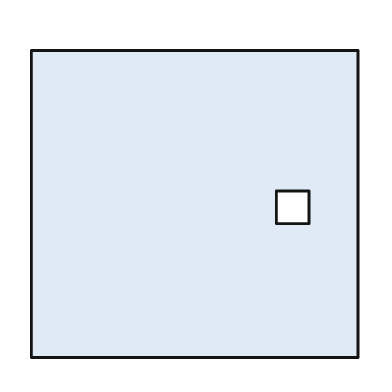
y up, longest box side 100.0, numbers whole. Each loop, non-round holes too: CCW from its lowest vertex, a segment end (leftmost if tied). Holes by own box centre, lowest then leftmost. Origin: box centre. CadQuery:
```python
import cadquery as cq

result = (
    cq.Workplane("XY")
    .moveTo(-50.0, -47.0)
    .lineTo(50.0, -47.0)
    .lineTo(50.0, 47.0)
    .lineTo(-50.0, 47.0)
    .close()
    .moveTo(25.0, -6.0)
    .lineTo(35.0, -6.0)
    .lineTo(35.0, 4.0)
    .lineTo(25.0, 4.0)
    .close()
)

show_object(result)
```